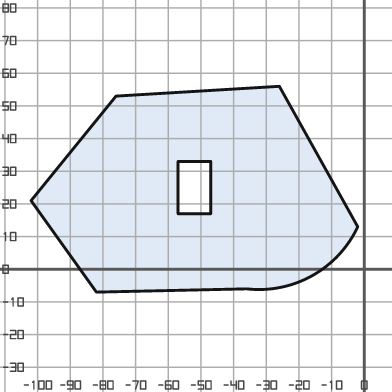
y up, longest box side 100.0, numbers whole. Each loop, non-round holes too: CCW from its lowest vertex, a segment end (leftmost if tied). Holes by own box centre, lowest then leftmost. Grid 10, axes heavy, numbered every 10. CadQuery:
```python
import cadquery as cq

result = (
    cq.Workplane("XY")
    .moveTo(-82.0, -7.0)
    .lineTo(-36.0, -6.0)
    .threePointArc((-16.0, -2.0), (-2.0, 13.0))
    .lineTo(-26.0, 56.0)
    .lineTo(-76.0, 53.0)
    .lineTo(-102.0, 21.0)
    .close()
    .moveTo(-57.0, 17.0)
    .lineTo(-47.0, 17.0)
    .lineTo(-47.0, 33.0)
    .lineTo(-57.0, 33.0)
    .close()
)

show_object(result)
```